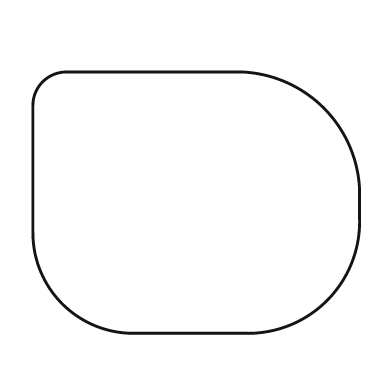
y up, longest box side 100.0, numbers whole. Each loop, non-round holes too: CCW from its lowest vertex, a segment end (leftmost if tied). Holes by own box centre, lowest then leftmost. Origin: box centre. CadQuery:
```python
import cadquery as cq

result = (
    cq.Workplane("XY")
    .moveTo(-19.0, -40.0)
    .lineTo(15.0, -40.0)
    .threePointArc((40.0, -30.0), (50.0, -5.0))
    .lineTo(50.0, 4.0)
    .threePointArc((39.0, 29.0), (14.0, 40.0))
    .lineTo(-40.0, 40.0)
    .threePointArc((-47.0, 37.0), (-50.0, 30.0))
    .lineTo(-50.0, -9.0)
    .threePointArc((-41.0, -31.0), (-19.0, -40.0))
    .close()
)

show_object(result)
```